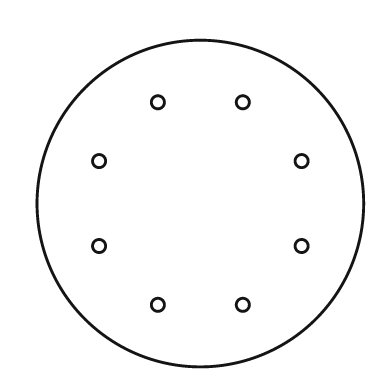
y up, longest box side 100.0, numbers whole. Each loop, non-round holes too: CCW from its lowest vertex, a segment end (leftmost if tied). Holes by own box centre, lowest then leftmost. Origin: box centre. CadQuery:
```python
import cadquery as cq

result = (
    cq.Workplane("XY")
    .moveTo(0.0, 0.0)
    .circle(50.0)
    .moveTo(-13.0, -31.0)
    .circle(2.0)
    .moveTo(13.0, -31.0)
    .circle(2.0)
    .moveTo(-31.0, -13.0)
    .circle(2.0)
    .moveTo(31.0, -13.0)
    .circle(2.0)
    .moveTo(-31.0, 13.0)
    .circle(2.0)
    .moveTo(31.0, 13.0)
    .circle(2.0)
    .moveTo(-13.0, 31.0)
    .circle(2.0)
    .moveTo(13.0, 31.0)
    .circle(2.0)
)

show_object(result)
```